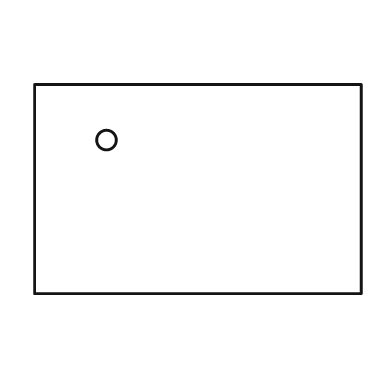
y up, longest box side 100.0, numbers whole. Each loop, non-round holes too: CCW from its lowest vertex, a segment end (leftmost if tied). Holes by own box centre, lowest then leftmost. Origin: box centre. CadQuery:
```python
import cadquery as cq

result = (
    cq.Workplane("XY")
    .moveTo(-50.0, -32.0)
    .lineTo(50.0, -32.0)
    .lineTo(50.0, 32.0)
    .lineTo(-50.0, 32.0)
    .close()
    .moveTo(-28.0, 15.0)
    .circle(3.0)
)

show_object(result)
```